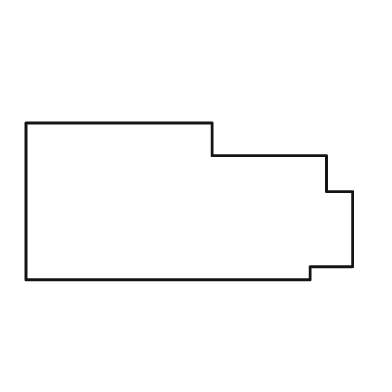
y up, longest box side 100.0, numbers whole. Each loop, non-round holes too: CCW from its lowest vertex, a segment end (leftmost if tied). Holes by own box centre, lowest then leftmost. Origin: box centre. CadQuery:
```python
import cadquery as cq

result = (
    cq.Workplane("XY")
    .moveTo(-50.0, -24.0)
    .lineTo(37.0, -24.0)
    .lineTo(37.0, -20.0)
    .lineTo(50.0, -20.0)
    .lineTo(50.0, 3.0)
    .lineTo(42.0, 3.0)
    .lineTo(42.0, 14.0)
    .lineTo(7.0, 14.0)
    .lineTo(7.0, 24.0)
    .lineTo(-50.0, 24.0)
    .close()
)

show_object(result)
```